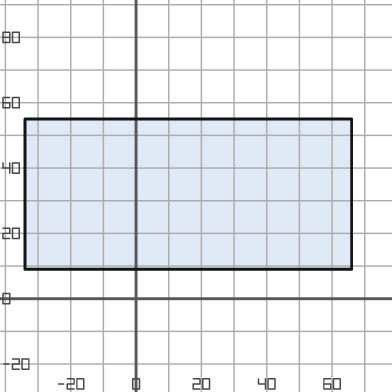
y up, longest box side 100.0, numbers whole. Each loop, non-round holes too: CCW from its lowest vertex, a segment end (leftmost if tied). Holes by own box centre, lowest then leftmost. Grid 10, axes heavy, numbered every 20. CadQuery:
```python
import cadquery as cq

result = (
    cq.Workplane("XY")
    .moveTo(-34.0, 9.0)
    .lineTo(66.0, 9.0)
    .lineTo(66.0, 55.0)
    .lineTo(-34.0, 55.0)
    .close()
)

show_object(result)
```